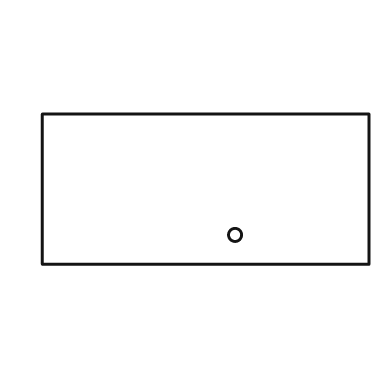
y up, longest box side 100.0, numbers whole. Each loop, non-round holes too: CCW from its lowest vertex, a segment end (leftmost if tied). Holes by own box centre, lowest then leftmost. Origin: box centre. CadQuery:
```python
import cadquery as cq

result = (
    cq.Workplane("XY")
    .moveTo(-50.0, -23.0)
    .lineTo(50.0, -23.0)
    .lineTo(50.0, 23.0)
    .lineTo(-50.0, 23.0)
    .close()
    .moveTo(9.0, -14.0)
    .circle(2.0)
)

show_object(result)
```